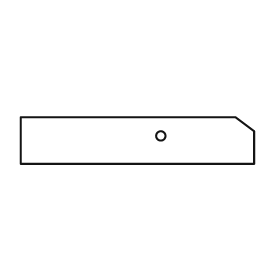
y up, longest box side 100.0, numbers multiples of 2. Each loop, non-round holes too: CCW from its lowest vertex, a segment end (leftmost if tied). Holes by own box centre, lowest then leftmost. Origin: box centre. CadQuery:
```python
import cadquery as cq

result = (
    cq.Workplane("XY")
    .moveTo(-50.0, -10.0)
    .lineTo(50.0, -10.0)
    .lineTo(50.0, 4.0)
    .lineTo(42.0, 10.0)
    .lineTo(-50.0, 10.0)
    .close()
    .moveTo(10.0, 2.0)
    .circle(2.0)
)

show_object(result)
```